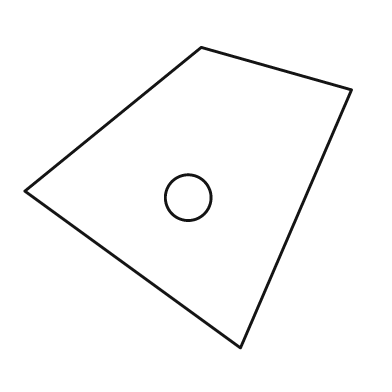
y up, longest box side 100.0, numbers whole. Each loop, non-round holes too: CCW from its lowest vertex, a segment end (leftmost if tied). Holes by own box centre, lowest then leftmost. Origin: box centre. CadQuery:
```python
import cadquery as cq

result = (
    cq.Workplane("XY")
    .moveTo(16.0, -46.0)
    .lineTo(50.0, 33.0)
    .lineTo(4.0, 46.0)
    .lineTo(-50.0, 2.0)
    .close()
    .moveTo(0.0, 0.0)
    .circle(7.0)
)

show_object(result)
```